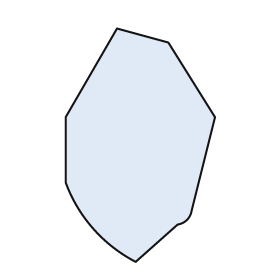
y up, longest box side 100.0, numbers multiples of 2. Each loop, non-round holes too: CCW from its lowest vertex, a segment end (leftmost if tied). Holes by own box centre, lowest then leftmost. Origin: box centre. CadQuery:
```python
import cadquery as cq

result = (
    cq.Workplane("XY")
    .moveTo(-2.0, -50.0)
    .lineTo(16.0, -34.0)
    .threePointArc((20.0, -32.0), (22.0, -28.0))
    .lineTo(32.0, 12.0)
    .lineTo(12.0, 44.0)
    .lineTo(-10.0, 50.0)
    .lineTo(-32.0, 12.0)
    .lineTo(-32.0, -16.0)
    .threePointArc((-20.0, -36.0), (-2.0, -50.0))
    .close()
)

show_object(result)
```